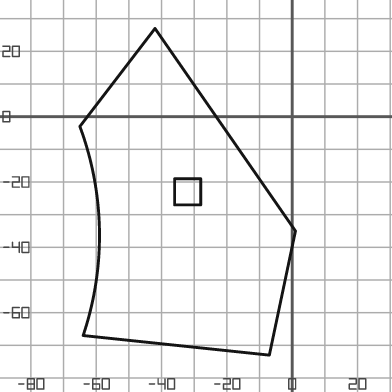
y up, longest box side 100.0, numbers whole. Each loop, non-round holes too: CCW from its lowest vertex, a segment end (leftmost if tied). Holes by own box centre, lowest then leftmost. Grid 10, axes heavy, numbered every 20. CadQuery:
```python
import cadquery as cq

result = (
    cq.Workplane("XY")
    .moveTo(-7.0, -73.0)
    .lineTo(1.0, -35.0)
    .lineTo(-42.0, 27.0)
    .lineTo(-65.0, -3.0)
    .threePointArc((-59.0, -35.0), (-64.0, -67.0))
    .close()
    .moveTo(-36.0, -27.0)
    .lineTo(-28.0, -27.0)
    .lineTo(-28.0, -19.0)
    .lineTo(-36.0, -19.0)
    .close()
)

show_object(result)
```